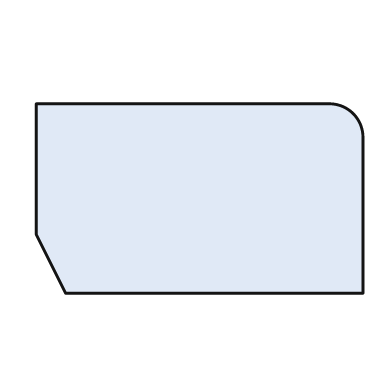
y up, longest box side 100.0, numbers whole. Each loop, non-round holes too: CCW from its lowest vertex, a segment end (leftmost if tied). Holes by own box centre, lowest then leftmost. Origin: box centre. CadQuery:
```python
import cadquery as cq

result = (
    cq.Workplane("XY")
    .moveTo(-41.0, -29.0)
    .lineTo(50.0, -29.0)
    .lineTo(50.0, 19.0)
    .threePointArc((47.0, 26.0), (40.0, 29.0))
    .lineTo(-50.0, 29.0)
    .lineTo(-50.0, -11.0)
    .close()
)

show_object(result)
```